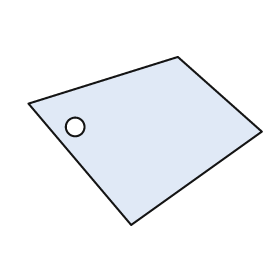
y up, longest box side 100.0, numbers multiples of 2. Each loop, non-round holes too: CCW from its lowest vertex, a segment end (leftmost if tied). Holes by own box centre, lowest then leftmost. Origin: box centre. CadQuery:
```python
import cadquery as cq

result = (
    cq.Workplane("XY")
    .moveTo(-6.0, -36.0)
    .lineTo(50.0, 4.0)
    .lineTo(14.0, 36.0)
    .lineTo(-50.0, 16.0)
    .close()
    .moveTo(-30.0, 6.0)
    .circle(4.0)
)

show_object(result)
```